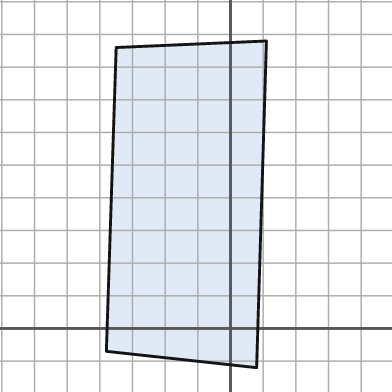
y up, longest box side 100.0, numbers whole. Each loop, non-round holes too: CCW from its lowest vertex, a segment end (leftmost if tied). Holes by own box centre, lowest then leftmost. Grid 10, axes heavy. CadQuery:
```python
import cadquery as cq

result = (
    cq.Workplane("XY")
    .moveTo(8.0, -12.0)
    .lineTo(11.0, 88.0)
    .lineTo(-35.0, 86.0)
    .lineTo(-38.0, -7.0)
    .close()
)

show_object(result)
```